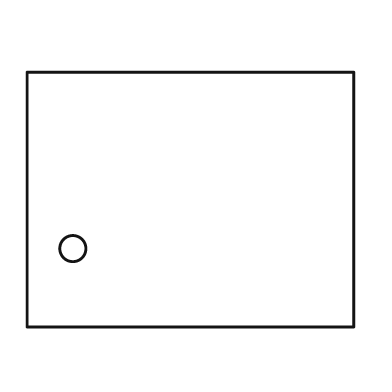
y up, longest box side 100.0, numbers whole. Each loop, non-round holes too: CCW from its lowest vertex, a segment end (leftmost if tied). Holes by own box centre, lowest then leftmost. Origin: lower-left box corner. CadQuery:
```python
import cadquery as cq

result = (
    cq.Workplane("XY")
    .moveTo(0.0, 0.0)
    .lineTo(100.0, 0.0)
    .lineTo(100.0, 78.0)
    .lineTo(0.0, 78.0)
    .close()
    .moveTo(14.0, 24.0)
    .circle(4.0)
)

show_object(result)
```